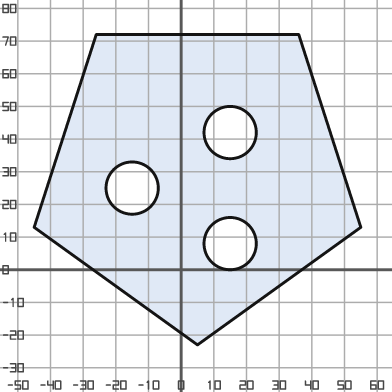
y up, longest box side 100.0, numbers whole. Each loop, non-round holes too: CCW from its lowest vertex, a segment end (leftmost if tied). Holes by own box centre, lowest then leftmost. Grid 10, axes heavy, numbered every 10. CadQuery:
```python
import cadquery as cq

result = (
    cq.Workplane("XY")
    .moveTo(5.0, -23.0)
    .lineTo(55.0, 13.0)
    .lineTo(36.0, 72.0)
    .lineTo(-26.0, 72.0)
    .lineTo(-45.0, 13.0)
    .close()
    .moveTo(15.0, 8.0)
    .circle(8.0)
    .moveTo(-15.0, 25.0)
    .circle(8.0)
    .moveTo(15.0, 42.0)
    .circle(8.0)
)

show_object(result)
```